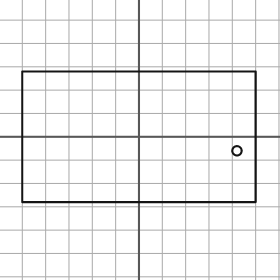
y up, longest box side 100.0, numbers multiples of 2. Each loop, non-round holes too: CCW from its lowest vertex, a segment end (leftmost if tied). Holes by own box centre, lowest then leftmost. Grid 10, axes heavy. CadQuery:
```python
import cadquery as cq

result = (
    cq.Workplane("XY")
    .moveTo(-50.0, -28.0)
    .lineTo(50.0, -28.0)
    .lineTo(50.0, 28.0)
    .lineTo(-50.0, 28.0)
    .close()
    .moveTo(42.0, -6.0)
    .circle(2.0)
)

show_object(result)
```